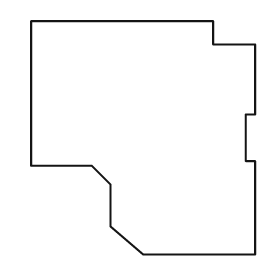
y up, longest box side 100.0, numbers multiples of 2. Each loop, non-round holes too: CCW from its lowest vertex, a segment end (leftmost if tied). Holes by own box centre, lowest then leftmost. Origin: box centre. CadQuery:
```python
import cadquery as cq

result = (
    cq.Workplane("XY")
    .moveTo(0.0, -50.0)
    .lineTo(48.0, -50.0)
    .lineTo(48.0, -10.0)
    .lineTo(44.0, -10.0)
    .lineTo(44.0, 10.0)
    .lineTo(48.0, 10.0)
    .lineTo(48.0, 40.0)
    .lineTo(30.0, 40.0)
    .lineTo(30.0, 50.0)
    .lineTo(-48.0, 50.0)
    .lineTo(-48.0, -12.0)
    .lineTo(-22.0, -12.0)
    .lineTo(-14.0, -20.0)
    .lineTo(-14.0, -38.0)
    .close()
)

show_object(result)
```